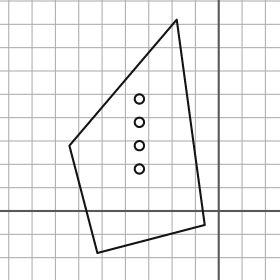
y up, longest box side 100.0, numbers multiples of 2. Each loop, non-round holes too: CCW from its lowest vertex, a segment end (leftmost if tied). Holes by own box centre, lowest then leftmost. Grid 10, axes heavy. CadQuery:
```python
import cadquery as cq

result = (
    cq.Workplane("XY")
    .moveTo(-52.0, -18.0)
    .lineTo(-6.0, -6.0)
    .lineTo(-18.0, 82.0)
    .lineTo(-64.0, 28.0)
    .close()
    .moveTo(-34.0, 18.0)
    .circle(2.0)
    .moveTo(-34.0, 28.0)
    .circle(2.0)
    .moveTo(-34.0, 38.0)
    .circle(2.0)
    .moveTo(-34.0, 48.0)
    .circle(2.0)
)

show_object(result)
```